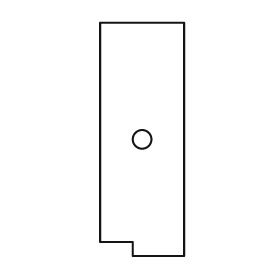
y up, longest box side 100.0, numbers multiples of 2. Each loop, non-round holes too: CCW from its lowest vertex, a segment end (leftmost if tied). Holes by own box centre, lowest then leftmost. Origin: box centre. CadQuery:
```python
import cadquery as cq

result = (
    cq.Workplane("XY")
    .moveTo(-4.0, -50.0)
    .lineTo(18.0, -50.0)
    .lineTo(18.0, 50.0)
    .lineTo(-18.0, 50.0)
    .lineTo(-18.0, -44.0)
    .lineTo(-4.0, -44.0)
    .close()
    .moveTo(0.0, 0.0)
    .circle(4.0)
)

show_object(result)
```